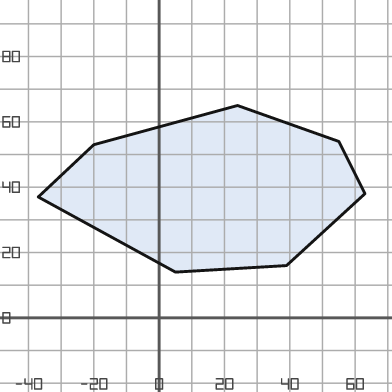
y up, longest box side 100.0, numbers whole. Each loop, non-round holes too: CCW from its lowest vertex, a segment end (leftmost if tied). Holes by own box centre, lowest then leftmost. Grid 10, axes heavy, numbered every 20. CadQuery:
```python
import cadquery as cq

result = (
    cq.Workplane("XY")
    .moveTo(5.0, 14.0)
    .lineTo(39.0, 16.0)
    .lineTo(63.0, 38.0)
    .lineTo(55.0, 54.0)
    .lineTo(24.0, 65.0)
    .lineTo(-20.0, 53.0)
    .lineTo(-37.0, 37.0)
    .close()
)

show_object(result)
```